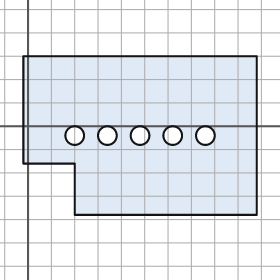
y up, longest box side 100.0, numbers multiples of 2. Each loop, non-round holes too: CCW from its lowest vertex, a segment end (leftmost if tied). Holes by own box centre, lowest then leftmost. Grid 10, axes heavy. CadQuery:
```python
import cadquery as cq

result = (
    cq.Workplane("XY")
    .moveTo(20.0, -38.0)
    .lineTo(98.0, -38.0)
    .lineTo(98.0, 30.0)
    .lineTo(-2.0, 30.0)
    .lineTo(-2.0, -16.0)
    .lineTo(20.0, -16.0)
    .close()
    .moveTo(20.0, -4.0)
    .circle(4.0)
    .moveTo(34.0, -4.0)
    .circle(4.0)
    .moveTo(48.0, -4.0)
    .circle(4.0)
    .moveTo(62.0, -4.0)
    .circle(4.0)
    .moveTo(76.0, -4.0)
    .circle(4.0)
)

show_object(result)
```